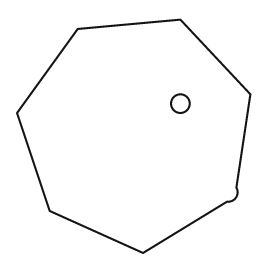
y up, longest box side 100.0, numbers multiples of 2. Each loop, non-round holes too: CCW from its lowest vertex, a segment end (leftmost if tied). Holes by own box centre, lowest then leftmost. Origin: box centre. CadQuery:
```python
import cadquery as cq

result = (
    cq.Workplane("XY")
    .moveTo(4.0, -50.0)
    .lineTo(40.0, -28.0)
    .threePointArc((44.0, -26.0), (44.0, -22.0))
    .lineTo(50.0, 18.0)
    .lineTo(20.0, 50.0)
    .lineTo(-24.0, 46.0)
    .lineTo(-50.0, 10.0)
    .lineTo(-36.0, -32.0)
    .close()
    .moveTo(20.0, 14.0)
    .circle(4.0)
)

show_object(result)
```